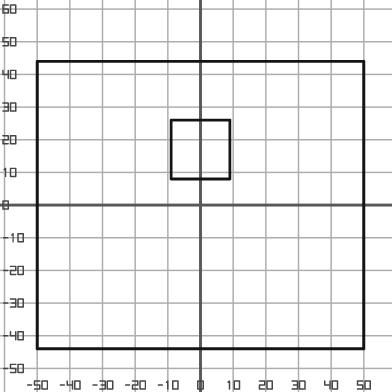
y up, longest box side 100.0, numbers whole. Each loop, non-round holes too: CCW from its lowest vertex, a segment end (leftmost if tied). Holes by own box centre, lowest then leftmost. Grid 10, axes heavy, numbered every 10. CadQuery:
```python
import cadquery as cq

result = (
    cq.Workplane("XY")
    .moveTo(-50.0, -44.0)
    .lineTo(50.0, -44.0)
    .lineTo(50.0, 44.0)
    .lineTo(-50.0, 44.0)
    .close()
    .moveTo(-9.0, 8.0)
    .lineTo(9.0, 8.0)
    .lineTo(9.0, 26.0)
    .lineTo(-9.0, 26.0)
    .close()
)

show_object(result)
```